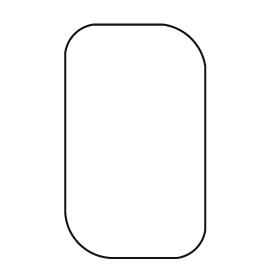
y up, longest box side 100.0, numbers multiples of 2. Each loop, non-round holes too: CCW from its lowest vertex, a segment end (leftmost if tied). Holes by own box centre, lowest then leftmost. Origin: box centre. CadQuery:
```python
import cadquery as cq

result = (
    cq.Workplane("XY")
    .moveTo(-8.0, -50.0)
    .lineTo(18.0, -50.0)
    .threePointArc((26.0, -46.0), (30.0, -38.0))
    .lineTo(30.0, 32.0)
    .threePointArc((24.0, 44.0), (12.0, 50.0))
    .lineTo(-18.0, 50.0)
    .threePointArc((-26.0, 46.0), (-30.0, 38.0))
    .lineTo(-30.0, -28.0)
    .threePointArc((-24.0, -44.0), (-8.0, -50.0))
    .close()
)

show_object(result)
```